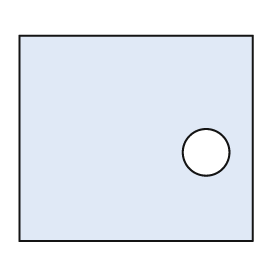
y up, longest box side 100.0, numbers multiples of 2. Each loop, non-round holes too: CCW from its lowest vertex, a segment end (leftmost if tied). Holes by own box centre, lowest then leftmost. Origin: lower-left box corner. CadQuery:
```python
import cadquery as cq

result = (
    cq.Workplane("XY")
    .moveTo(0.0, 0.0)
    .lineTo(100.0, 0.0)
    .lineTo(100.0, 88.0)
    .lineTo(0.0, 88.0)
    .close()
    .moveTo(80.0, 38.0)
    .circle(10.0)
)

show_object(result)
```